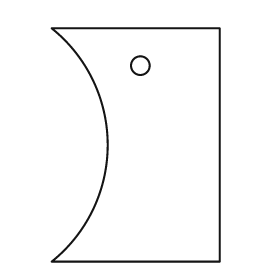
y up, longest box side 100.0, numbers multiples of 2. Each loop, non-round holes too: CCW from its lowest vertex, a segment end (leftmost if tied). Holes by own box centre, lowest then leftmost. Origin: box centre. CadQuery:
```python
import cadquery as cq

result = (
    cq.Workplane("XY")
    .moveTo(-36.0, -50.0)
    .lineTo(36.0, -50.0)
    .lineTo(36.0, 50.0)
    .lineTo(-36.0, 50.0)
    .threePointArc((-12.0, 0.0), (-36.0, -50.0))
    .close()
    .moveTo(2.0, 34.0)
    .circle(4.0)
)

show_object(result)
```